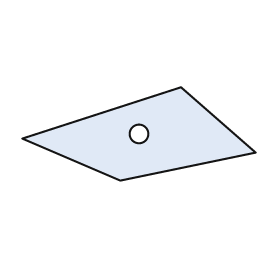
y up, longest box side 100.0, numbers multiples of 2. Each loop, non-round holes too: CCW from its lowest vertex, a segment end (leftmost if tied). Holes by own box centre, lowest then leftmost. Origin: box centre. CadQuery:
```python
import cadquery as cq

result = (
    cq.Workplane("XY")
    .moveTo(-8.0, -20.0)
    .lineTo(50.0, -8.0)
    .lineTo(18.0, 20.0)
    .lineTo(-50.0, -2.0)
    .close()
    .moveTo(0.0, 0.0)
    .circle(4.0)
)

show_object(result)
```